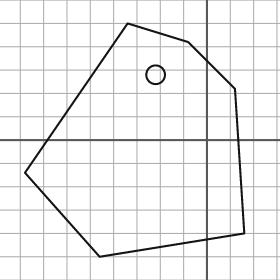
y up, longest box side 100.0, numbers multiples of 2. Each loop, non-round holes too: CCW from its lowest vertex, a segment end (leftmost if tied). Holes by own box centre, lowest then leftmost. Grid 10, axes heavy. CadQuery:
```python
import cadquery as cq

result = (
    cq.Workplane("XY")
    .moveTo(-46.0, -50.0)
    .lineTo(16.0, -40.0)
    .lineTo(12.0, 22.0)
    .lineTo(-8.0, 42.0)
    .lineTo(-34.0, 50.0)
    .lineTo(-78.0, -14.0)
    .close()
    .moveTo(-22.0, 28.0)
    .circle(4.0)
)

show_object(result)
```